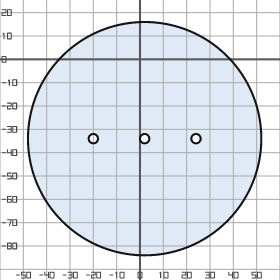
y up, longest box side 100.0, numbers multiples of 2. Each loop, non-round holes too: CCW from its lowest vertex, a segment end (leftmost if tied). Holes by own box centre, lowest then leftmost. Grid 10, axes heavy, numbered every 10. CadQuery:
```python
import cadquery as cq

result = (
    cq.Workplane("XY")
    .moveTo(2.0, -34.0)
    .circle(50.0)
    .moveTo(-20.0, -34.0)
    .circle(2.0)
    .moveTo(2.0, -34.0)
    .circle(2.0)
    .moveTo(24.0, -34.0)
    .circle(2.0)
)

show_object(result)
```